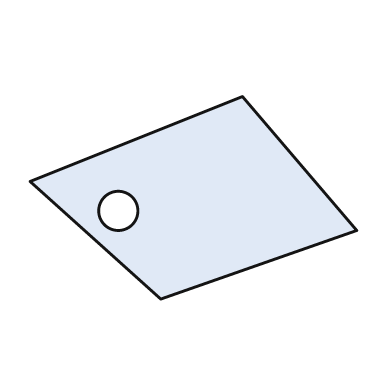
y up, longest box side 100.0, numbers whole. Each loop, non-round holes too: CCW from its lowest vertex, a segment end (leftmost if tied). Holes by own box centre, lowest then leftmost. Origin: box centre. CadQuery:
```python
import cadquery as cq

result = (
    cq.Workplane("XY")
    .moveTo(-10.0, -31.0)
    .lineTo(50.0, -10.0)
    .lineTo(15.0, 31.0)
    .lineTo(-50.0, 5.0)
    .close()
    .moveTo(-23.0, -4.0)
    .circle(6.0)
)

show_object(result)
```